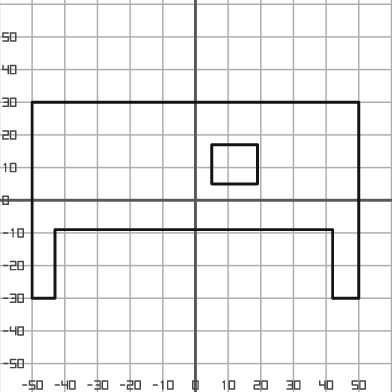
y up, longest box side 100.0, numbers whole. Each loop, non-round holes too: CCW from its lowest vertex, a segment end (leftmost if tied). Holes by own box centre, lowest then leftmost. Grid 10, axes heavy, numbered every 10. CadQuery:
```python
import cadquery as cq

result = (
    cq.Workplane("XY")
    .moveTo(-50.0, -30.0)
    .lineTo(-43.0, -30.0)
    .lineTo(-43.0, -9.0)
    .lineTo(42.0, -9.0)
    .lineTo(42.0, -30.0)
    .lineTo(50.0, -30.0)
    .lineTo(50.0, 30.0)
    .lineTo(-50.0, 30.0)
    .close()
    .moveTo(5.0, 5.0)
    .lineTo(19.0, 5.0)
    .lineTo(19.0, 17.0)
    .lineTo(5.0, 17.0)
    .close()
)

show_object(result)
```